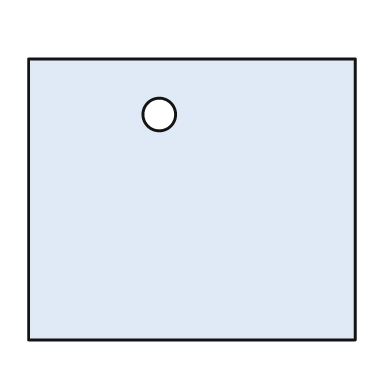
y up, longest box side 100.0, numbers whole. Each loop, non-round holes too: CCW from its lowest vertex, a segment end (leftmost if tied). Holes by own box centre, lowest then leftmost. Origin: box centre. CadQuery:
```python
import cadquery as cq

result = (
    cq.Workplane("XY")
    .moveTo(-50.0, -43.0)
    .lineTo(50.0, -43.0)
    .lineTo(50.0, 43.0)
    .lineTo(-50.0, 43.0)
    .close()
    .moveTo(-10.0, 26.0)
    .circle(5.0)
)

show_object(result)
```